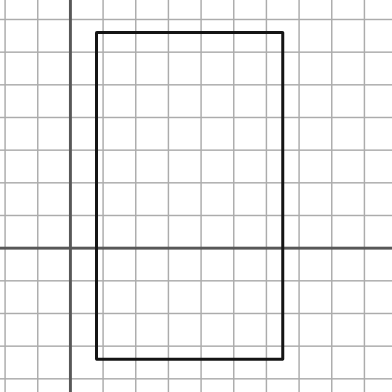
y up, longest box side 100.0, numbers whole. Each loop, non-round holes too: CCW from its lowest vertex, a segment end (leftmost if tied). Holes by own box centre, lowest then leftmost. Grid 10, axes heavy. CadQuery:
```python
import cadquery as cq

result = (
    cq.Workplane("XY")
    .moveTo(8.0, -34.0)
    .lineTo(65.0, -34.0)
    .lineTo(65.0, 66.0)
    .lineTo(8.0, 66.0)
    .close()
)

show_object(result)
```